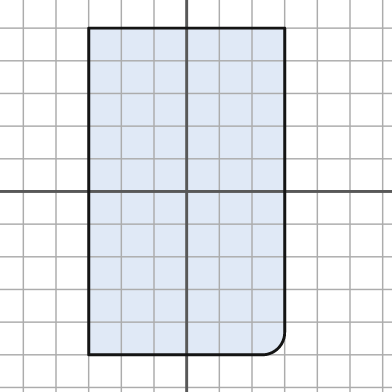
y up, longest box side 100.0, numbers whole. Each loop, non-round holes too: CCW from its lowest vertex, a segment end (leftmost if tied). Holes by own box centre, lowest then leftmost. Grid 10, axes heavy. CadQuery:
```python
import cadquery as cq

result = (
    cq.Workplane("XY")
    .moveTo(-30.0, -50.0)
    .lineTo(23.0, -50.0)
    .threePointArc((28.0, -48.0), (30.0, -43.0))
    .lineTo(30.0, 50.0)
    .lineTo(-30.0, 50.0)
    .close()
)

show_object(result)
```